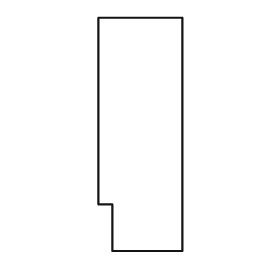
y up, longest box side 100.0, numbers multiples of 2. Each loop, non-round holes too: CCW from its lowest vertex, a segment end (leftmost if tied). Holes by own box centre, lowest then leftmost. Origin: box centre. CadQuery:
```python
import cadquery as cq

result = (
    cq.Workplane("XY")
    .moveTo(-12.0, -50.0)
    .lineTo(18.0, -50.0)
    .lineTo(18.0, 50.0)
    .lineTo(-18.0, 50.0)
    .lineTo(-18.0, -30.0)
    .lineTo(-12.0, -30.0)
    .close()
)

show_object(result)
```